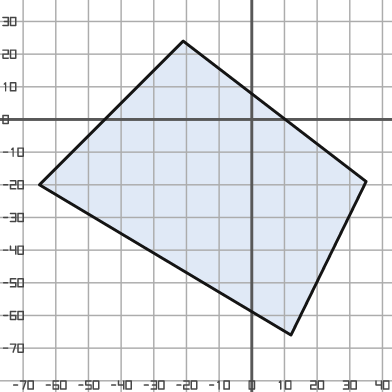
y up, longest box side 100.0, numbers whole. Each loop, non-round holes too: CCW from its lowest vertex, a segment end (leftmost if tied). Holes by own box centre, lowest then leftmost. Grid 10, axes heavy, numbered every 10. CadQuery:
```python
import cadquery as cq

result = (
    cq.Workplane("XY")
    .moveTo(12.0, -66.0)
    .lineTo(35.0, -19.0)
    .lineTo(-21.0, 24.0)
    .lineTo(-65.0, -20.0)
    .close()
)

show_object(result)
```